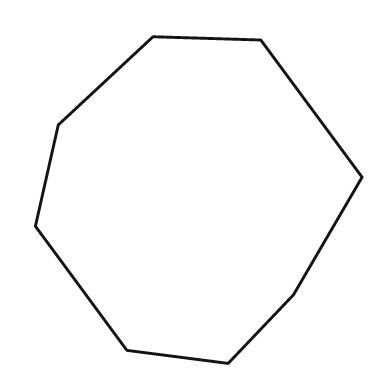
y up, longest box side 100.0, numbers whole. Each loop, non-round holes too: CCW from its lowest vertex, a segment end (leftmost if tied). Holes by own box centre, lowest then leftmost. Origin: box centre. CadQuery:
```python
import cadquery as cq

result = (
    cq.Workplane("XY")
    .moveTo(9.0, -50.0)
    .lineTo(29.0, -29.0)
    .lineTo(50.0, 7.0)
    .lineTo(19.0, 49.0)
    .lineTo(-14.0, 50.0)
    .lineTo(-43.0, 23.0)
    .lineTo(-50.0, -8.0)
    .lineTo(-22.0, -46.0)
    .close()
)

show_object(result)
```